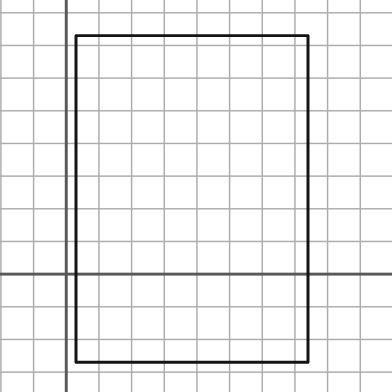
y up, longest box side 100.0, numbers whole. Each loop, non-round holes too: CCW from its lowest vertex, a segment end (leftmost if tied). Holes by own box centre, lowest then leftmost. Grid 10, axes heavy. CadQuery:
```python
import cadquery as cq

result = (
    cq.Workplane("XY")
    .moveTo(3.0, -27.0)
    .lineTo(74.0, -27.0)
    .lineTo(74.0, 73.0)
    .lineTo(3.0, 73.0)
    .close()
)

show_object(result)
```